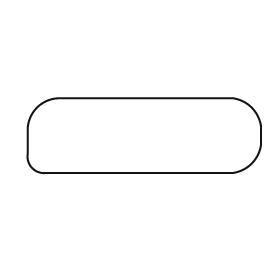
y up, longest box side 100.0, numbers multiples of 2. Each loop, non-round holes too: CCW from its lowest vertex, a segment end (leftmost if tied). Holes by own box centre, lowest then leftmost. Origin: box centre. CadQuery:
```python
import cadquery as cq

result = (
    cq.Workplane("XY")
    .moveTo(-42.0, -16.0)
    .lineTo(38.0, -16.0)
    .threePointArc((46.0, -12.0), (50.0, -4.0))
    .lineTo(50.0, 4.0)
    .threePointArc((46.0, 12.0), (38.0, 16.0))
    .lineTo(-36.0, 16.0)
    .threePointArc((-46.0, 12.0), (-50.0, 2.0))
    .lineTo(-50.0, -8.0)
    .threePointArc((-48.0, -14.0), (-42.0, -16.0))
    .close()
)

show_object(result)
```